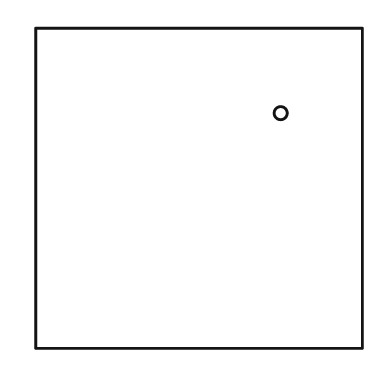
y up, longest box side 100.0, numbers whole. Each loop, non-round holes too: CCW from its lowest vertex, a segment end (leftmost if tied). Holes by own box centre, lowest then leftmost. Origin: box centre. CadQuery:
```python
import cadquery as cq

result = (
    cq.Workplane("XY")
    .moveTo(-50.0, -49.0)
    .lineTo(50.0, -49.0)
    .lineTo(50.0, 49.0)
    .lineTo(-50.0, 49.0)
    .close()
    .moveTo(25.0, 23.0)
    .circle(2.0)
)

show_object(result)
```